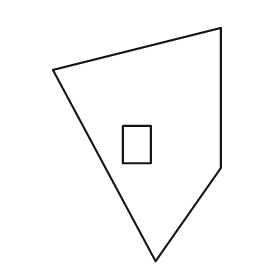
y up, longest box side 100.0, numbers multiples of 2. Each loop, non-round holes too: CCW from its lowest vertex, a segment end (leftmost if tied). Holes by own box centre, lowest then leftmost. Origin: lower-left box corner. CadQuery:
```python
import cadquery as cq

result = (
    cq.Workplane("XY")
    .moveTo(44.0, 0.0)
    .lineTo(72.0, 40.0)
    .lineTo(72.0, 100.0)
    .lineTo(0.0, 82.0)
    .close()
    .moveTo(30.0, 42.0)
    .lineTo(42.0, 42.0)
    .lineTo(42.0, 58.0)
    .lineTo(30.0, 58.0)
    .close()
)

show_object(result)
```